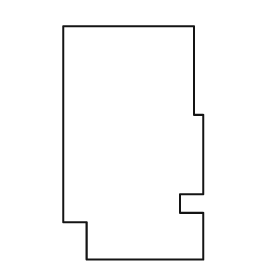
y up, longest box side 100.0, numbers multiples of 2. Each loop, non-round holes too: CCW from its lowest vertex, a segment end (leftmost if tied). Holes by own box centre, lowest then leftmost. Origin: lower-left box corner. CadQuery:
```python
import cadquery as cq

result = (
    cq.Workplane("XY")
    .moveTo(10.0, 0.0)
    .lineTo(60.0, 0.0)
    .lineTo(60.0, 20.0)
    .lineTo(50.0, 20.0)
    .lineTo(50.0, 28.0)
    .lineTo(60.0, 28.0)
    .lineTo(60.0, 62.0)
    .lineTo(56.0, 62.0)
    .lineTo(56.0, 100.0)
    .lineTo(0.0, 100.0)
    .lineTo(0.0, 16.0)
    .lineTo(10.0, 16.0)
    .close()
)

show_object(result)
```